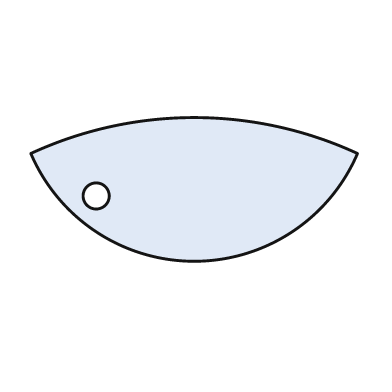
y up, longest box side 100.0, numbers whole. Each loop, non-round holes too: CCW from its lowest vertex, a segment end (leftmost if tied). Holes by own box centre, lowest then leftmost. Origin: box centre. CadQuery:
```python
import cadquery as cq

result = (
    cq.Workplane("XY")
    .moveTo(-50.0, 11.0)
    .threePointArc((0.0, -22.0), (50.0, 11.0))
    .threePointArc((0.0, 22.0), (-50.0, 11.0))
    .close()
    .moveTo(-30.0, -2.0)
    .circle(4.0)
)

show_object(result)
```